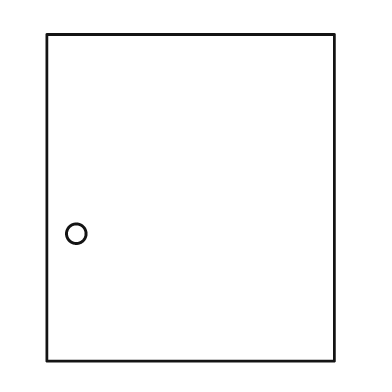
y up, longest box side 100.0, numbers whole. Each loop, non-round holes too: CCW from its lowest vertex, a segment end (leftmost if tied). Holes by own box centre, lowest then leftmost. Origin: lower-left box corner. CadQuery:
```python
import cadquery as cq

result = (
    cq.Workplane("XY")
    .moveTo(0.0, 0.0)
    .lineTo(88.0, 0.0)
    .lineTo(88.0, 100.0)
    .lineTo(0.0, 100.0)
    .close()
    .moveTo(9.0, 39.0)
    .circle(3.0)
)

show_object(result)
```